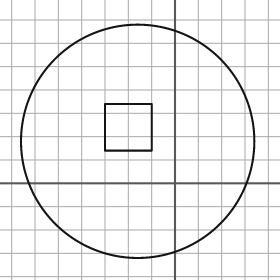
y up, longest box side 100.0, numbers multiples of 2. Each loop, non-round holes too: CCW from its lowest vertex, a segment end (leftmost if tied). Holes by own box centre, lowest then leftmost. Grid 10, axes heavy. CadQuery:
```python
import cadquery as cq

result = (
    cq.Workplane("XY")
    .moveTo(-16.0, 18.0)
    .circle(50.0)
    .moveTo(-30.0, 14.0)
    .lineTo(-10.0, 14.0)
    .lineTo(-10.0, 34.0)
    .lineTo(-30.0, 34.0)
    .close()
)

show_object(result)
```